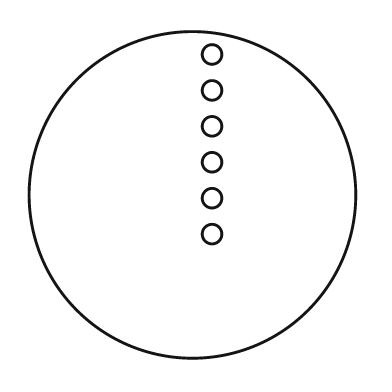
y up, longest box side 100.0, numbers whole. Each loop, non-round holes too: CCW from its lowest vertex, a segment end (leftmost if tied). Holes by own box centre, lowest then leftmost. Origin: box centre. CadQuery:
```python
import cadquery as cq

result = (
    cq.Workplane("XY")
    .moveTo(0.0, 0.0)
    .circle(50.0)
    .moveTo(6.0, -12.0)
    .circle(3.0)
    .moveTo(6.0, -1.0)
    .circle(3.0)
    .moveTo(6.0, 10.0)
    .circle(3.0)
    .moveTo(6.0, 21.0)
    .circle(3.0)
    .moveTo(6.0, 32.0)
    .circle(3.0)
    .moveTo(6.0, 43.0)
    .circle(3.0)
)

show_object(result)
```